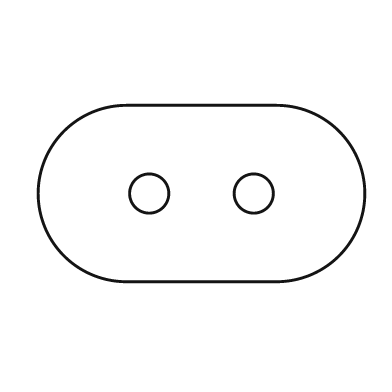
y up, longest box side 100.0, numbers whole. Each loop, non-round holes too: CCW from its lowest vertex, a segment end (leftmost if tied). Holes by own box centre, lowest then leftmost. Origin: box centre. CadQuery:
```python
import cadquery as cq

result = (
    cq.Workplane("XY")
    .moveTo(-23.0, -27.0)
    .lineTo(23.0, -27.0)
    .threePointArc((50.0, 0.0), (23.0, 27.0))
    .lineTo(-23.0, 27.0)
    .threePointArc((-50.0, 0.0), (-23.0, -27.0))
    .close()
    .moveTo(-16.0, 0.0)
    .circle(6.0)
    .moveTo(16.0, 0.0)
    .circle(6.0)
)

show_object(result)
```